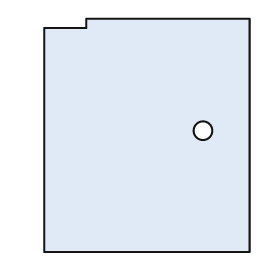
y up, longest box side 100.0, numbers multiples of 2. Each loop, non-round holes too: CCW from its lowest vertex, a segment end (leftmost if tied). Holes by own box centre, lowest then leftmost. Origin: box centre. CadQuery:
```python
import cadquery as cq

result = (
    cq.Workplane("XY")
    .moveTo(-44.0, -50.0)
    .lineTo(44.0, -50.0)
    .lineTo(44.0, 50.0)
    .lineTo(-26.0, 50.0)
    .lineTo(-26.0, 46.0)
    .lineTo(-44.0, 46.0)
    .close()
    .moveTo(24.0, 2.0)
    .circle(4.0)
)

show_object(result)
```